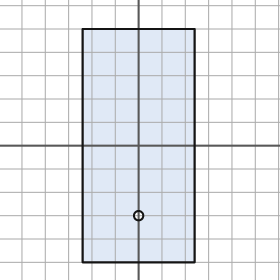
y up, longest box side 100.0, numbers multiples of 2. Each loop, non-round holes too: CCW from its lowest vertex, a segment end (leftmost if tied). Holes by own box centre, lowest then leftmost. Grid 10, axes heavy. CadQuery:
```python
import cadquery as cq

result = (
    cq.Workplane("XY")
    .moveTo(-24.0, -50.0)
    .lineTo(24.0, -50.0)
    .lineTo(24.0, 50.0)
    .lineTo(-24.0, 50.0)
    .close()
    .moveTo(0.0, -30.0)
    .circle(2.0)
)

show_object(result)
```